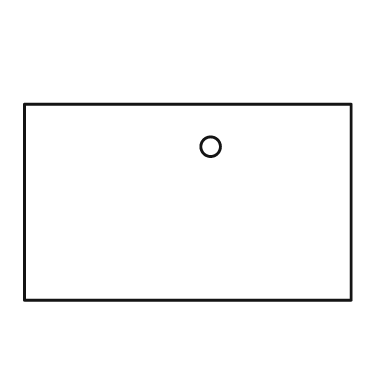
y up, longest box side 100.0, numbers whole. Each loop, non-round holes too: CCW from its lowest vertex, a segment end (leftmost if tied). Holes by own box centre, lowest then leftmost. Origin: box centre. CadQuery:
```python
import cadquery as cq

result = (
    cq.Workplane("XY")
    .moveTo(-50.0, -30.0)
    .lineTo(50.0, -30.0)
    .lineTo(50.0, 30.0)
    .lineTo(-50.0, 30.0)
    .close()
    .moveTo(7.0, 17.0)
    .circle(3.0)
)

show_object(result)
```